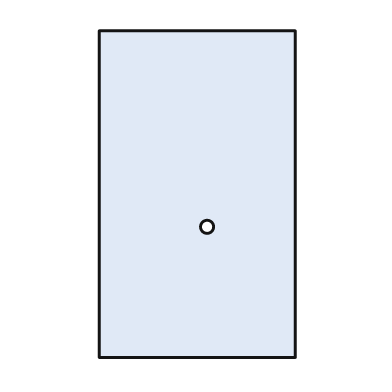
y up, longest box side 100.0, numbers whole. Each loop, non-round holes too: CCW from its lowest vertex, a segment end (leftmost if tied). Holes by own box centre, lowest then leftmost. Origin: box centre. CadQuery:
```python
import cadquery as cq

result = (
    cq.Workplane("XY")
    .moveTo(-30.0, -50.0)
    .lineTo(30.0, -50.0)
    .lineTo(30.0, 50.0)
    .lineTo(-30.0, 50.0)
    .close()
    .moveTo(3.0, -10.0)
    .circle(2.0)
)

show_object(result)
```